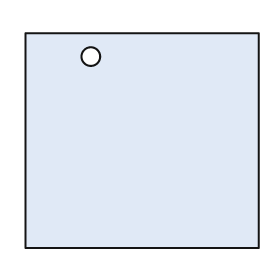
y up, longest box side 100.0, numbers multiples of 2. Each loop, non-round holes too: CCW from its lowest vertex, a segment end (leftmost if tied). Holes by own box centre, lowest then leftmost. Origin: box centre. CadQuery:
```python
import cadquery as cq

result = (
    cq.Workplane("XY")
    .moveTo(-50.0, -46.0)
    .lineTo(50.0, -46.0)
    .lineTo(50.0, 46.0)
    .lineTo(-50.0, 46.0)
    .close()
    .moveTo(-22.0, 36.0)
    .circle(4.0)
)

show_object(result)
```